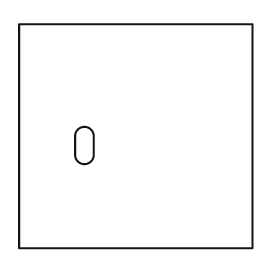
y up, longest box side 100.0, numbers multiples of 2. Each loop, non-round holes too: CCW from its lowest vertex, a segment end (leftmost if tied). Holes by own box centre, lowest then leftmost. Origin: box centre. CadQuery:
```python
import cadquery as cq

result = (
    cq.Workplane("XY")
    .moveTo(-50.0, -48.0)
    .lineTo(50.0, -48.0)
    .lineTo(50.0, 48.0)
    .lineTo(-50.0, 48.0)
    .close()
    .moveTo(-26.0, -8.0)
    .threePointArc((-22.0, -12.0), (-18.0, -8.0))
    .lineTo(-18.0, 0.0)
    .threePointArc((-22.0, 4.0), (-26.0, 0.0))
    .close()
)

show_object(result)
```